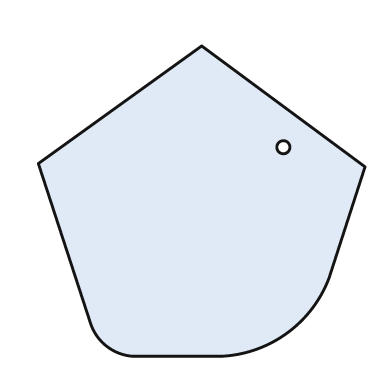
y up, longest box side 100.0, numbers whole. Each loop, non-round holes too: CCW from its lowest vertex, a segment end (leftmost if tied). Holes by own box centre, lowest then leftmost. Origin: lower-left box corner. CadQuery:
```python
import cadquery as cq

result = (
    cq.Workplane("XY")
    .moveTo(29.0, 0.0)
    .lineTo(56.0, 0.0)
    .threePointArc((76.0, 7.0), (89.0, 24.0))
    .lineTo(100.0, 58.0)
    .lineTo(50.0, 95.0)
    .lineTo(0.0, 59.0)
    .lineTo(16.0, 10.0)
    .threePointArc((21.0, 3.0), (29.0, 0.0))
    .close()
    .moveTo(75.0, 64.0)
    .circle(2.0)
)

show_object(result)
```